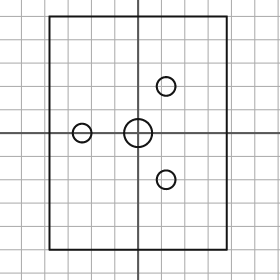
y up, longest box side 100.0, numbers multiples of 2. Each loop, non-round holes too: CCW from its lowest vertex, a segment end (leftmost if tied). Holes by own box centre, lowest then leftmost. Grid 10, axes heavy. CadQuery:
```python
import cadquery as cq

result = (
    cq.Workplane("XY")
    .moveTo(-38.0, -50.0)
    .lineTo(38.0, -50.0)
    .lineTo(38.0, 50.0)
    .lineTo(-38.0, 50.0)
    .close()
    .moveTo(12.0, -20.0)
    .circle(4.0)
    .moveTo(-24.0, 0.0)
    .circle(4.0)
    .moveTo(0.0, 0.0)
    .circle(6.0)
    .moveTo(12.0, 20.0)
    .circle(4.0)
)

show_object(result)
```